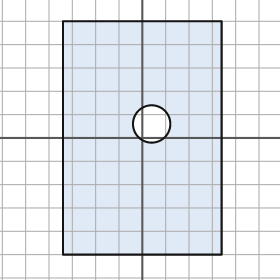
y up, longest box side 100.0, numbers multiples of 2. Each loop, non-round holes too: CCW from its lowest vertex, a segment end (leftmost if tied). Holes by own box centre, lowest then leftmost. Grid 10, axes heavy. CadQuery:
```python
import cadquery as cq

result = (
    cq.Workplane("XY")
    .moveTo(-34.0, -50.0)
    .lineTo(34.0, -50.0)
    .lineTo(34.0, 50.0)
    .lineTo(-34.0, 50.0)
    .close()
    .moveTo(4.0, 6.0)
    .circle(8.0)
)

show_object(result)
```